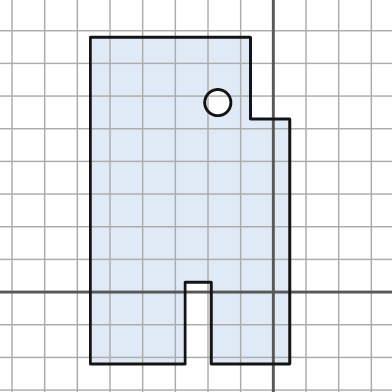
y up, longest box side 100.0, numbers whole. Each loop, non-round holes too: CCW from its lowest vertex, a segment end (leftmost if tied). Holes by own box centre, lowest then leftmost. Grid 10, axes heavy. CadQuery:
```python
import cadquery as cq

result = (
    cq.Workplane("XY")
    .moveTo(-56.0, -22.0)
    .lineTo(-27.0, -22.0)
    .lineTo(-27.0, 3.0)
    .lineTo(-19.0, 3.0)
    .lineTo(-19.0, -22.0)
    .lineTo(5.0, -22.0)
    .lineTo(5.0, 53.0)
    .lineTo(-7.0, 53.0)
    .lineTo(-7.0, 78.0)
    .lineTo(-56.0, 78.0)
    .close()
    .moveTo(-17.0, 58.0)
    .circle(4.0)
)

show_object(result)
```